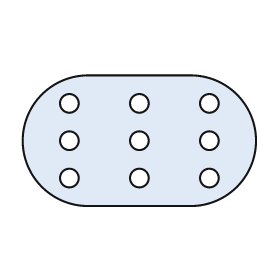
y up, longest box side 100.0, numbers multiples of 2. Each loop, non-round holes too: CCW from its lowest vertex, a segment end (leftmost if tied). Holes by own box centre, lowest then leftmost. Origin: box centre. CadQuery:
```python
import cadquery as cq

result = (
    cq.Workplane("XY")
    .moveTo(-22.0, -28.0)
    .lineTo(22.0, -28.0)
    .threePointArc((50.0, 0.0), (22.0, 28.0))
    .lineTo(-22.0, 28.0)
    .threePointArc((-50.0, 0.0), (-22.0, -28.0))
    .close()
    .moveTo(-30.0, -16.0)
    .circle(4.0)
    .moveTo(0.0, -16.0)
    .circle(4.0)
    .moveTo(30.0, -16.0)
    .circle(4.0)
    .moveTo(-30.0, 0.0)
    .circle(4.0)
    .moveTo(0.0, 0.0)
    .circle(4.0)
    .moveTo(30.0, 0.0)
    .circle(4.0)
    .moveTo(-30.0, 16.0)
    .circle(4.0)
    .moveTo(0.0, 16.0)
    .circle(4.0)
    .moveTo(30.0, 16.0)
    .circle(4.0)
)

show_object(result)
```